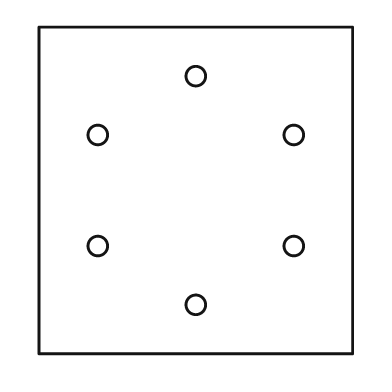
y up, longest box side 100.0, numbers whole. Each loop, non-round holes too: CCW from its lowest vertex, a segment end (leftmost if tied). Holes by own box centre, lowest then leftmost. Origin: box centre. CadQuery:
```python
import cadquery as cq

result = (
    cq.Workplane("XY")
    .moveTo(-48.0, -50.0)
    .lineTo(48.0, -50.0)
    .lineTo(48.0, 50.0)
    .lineTo(-48.0, 50.0)
    .close()
    .moveTo(0.0, -35.0)
    .circle(3.0)
    .moveTo(-30.0, -17.0)
    .circle(3.0)
    .moveTo(30.0, -17.0)
    .circle(3.0)
    .moveTo(-30.0, 17.0)
    .circle(3.0)
    .moveTo(30.0, 17.0)
    .circle(3.0)
    .moveTo(0.0, 35.0)
    .circle(3.0)
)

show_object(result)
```